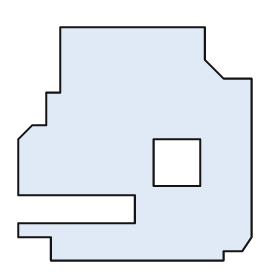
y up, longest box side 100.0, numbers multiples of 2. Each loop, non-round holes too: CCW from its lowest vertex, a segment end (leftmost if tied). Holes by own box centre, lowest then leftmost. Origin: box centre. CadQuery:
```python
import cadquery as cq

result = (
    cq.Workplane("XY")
    .moveTo(-36.0, -50.0)
    .lineTo(38.0, -50.0)
    .lineTo(38.0, -46.0)
    .lineTo(46.0, -46.0)
    .lineTo(50.0, -40.0)
    .lineTo(50.0, 28.0)
    .lineTo(38.0, 28.0)
    .lineTo(30.0, 36.0)
    .lineTo(30.0, 50.0)
    .lineTo(-32.0, 50.0)
    .lineTo(-32.0, 22.0)
    .lineTo(-38.0, 22.0)
    .lineTo(-38.0, 8.0)
    .lineTo(-44.0, 8.0)
    .lineTo(-50.0, 2.0)
    .lineTo(-50.0, -22.0)
    .lineTo(0.0, -22.0)
    .lineTo(0.0, -34.0)
    .lineTo(-50.0, -34.0)
    .lineTo(-50.0, -40.0)
    .lineTo(-36.0, -40.0)
    .close()
    .moveTo(8.0, -18.0)
    .lineTo(28.0, -18.0)
    .lineTo(28.0, 2.0)
    .lineTo(8.0, 2.0)
    .close()
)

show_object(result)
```